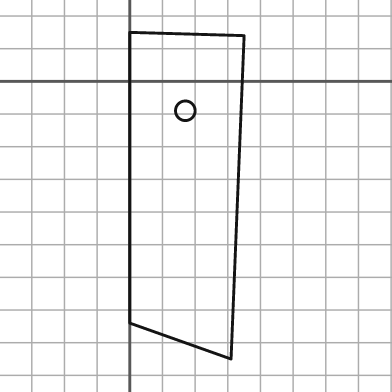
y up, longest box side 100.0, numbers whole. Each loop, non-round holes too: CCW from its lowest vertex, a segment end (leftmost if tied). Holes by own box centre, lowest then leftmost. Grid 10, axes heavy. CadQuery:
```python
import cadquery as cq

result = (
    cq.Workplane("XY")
    .moveTo(31.0, -85.0)
    .lineTo(35.0, 14.0)
    .lineTo(0.0, 15.0)
    .lineTo(0.0, -74.0)
    .close()
    .moveTo(17.0, -9.0)
    .circle(3.0)
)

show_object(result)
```